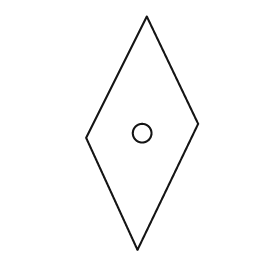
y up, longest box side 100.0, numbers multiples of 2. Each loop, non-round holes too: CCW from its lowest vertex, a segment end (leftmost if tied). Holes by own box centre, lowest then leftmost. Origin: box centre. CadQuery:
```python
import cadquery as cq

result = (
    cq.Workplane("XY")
    .moveTo(-2.0, -50.0)
    .lineTo(24.0, 4.0)
    .lineTo(2.0, 50.0)
    .lineTo(-24.0, -2.0)
    .close()
    .moveTo(0.0, 0.0)
    .circle(4.0)
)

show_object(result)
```